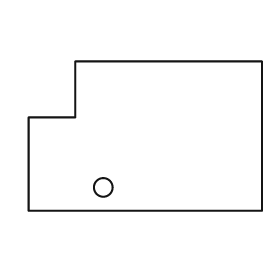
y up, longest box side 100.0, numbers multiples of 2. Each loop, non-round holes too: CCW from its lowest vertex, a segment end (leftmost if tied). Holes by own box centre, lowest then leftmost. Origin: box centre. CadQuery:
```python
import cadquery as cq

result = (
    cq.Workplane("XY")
    .moveTo(-50.0, -32.0)
    .lineTo(50.0, -32.0)
    .lineTo(50.0, 32.0)
    .lineTo(-30.0, 32.0)
    .lineTo(-30.0, 8.0)
    .lineTo(-50.0, 8.0)
    .close()
    .moveTo(-18.0, -22.0)
    .circle(4.0)
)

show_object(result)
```